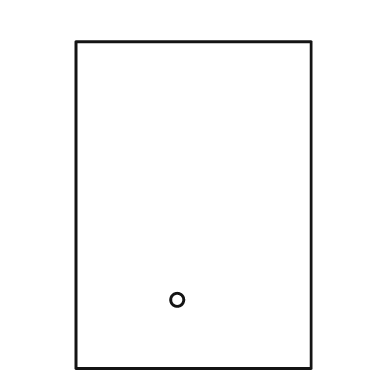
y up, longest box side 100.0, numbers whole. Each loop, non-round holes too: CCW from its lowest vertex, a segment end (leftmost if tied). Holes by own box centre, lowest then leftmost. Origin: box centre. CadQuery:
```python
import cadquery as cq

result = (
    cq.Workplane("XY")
    .moveTo(-36.0, -50.0)
    .lineTo(36.0, -50.0)
    .lineTo(36.0, 50.0)
    .lineTo(-36.0, 50.0)
    .close()
    .moveTo(-5.0, -29.0)
    .circle(2.0)
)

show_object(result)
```